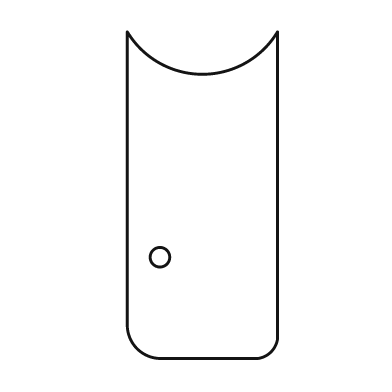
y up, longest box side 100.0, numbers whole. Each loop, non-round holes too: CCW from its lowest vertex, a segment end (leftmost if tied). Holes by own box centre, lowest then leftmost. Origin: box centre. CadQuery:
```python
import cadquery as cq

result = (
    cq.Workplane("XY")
    .moveTo(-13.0, -50.0)
    .lineTo(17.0, -50.0)
    .threePointArc((21.0, -48.0), (23.0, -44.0))
    .lineTo(23.0, 50.0)
    .threePointArc((0.0, 37.0), (-23.0, 50.0))
    .lineTo(-23.0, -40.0)
    .threePointArc((-20.0, -47.0), (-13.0, -50.0))
    .close()
    .moveTo(-13.0, -19.0)
    .circle(3.0)
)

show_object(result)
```